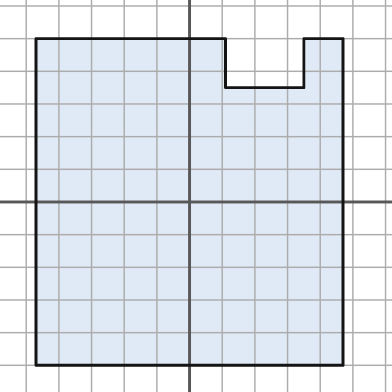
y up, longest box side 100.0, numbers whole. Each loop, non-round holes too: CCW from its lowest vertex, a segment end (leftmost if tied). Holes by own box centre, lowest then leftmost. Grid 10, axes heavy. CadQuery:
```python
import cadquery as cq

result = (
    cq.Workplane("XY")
    .moveTo(-47.0, -50.0)
    .lineTo(47.0, -50.0)
    .lineTo(47.0, 50.0)
    .lineTo(35.0, 50.0)
    .lineTo(35.0, 35.0)
    .lineTo(11.0, 35.0)
    .lineTo(11.0, 50.0)
    .lineTo(-47.0, 50.0)
    .close()
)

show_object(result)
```